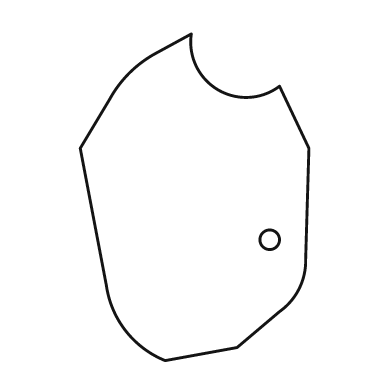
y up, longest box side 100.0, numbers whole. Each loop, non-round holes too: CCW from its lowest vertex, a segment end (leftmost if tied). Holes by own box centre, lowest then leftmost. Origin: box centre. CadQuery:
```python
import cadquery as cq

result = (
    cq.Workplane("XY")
    .moveTo(-9.0, -50.0)
    .lineTo(13.0, -46.0)
    .lineTo(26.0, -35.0)
    .threePointArc((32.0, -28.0), (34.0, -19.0))
    .lineTo(35.0, 15.0)
    .lineTo(26.0, 34.0)
    .threePointArc((7.0, 33.0), (-1.0, 50.0))
    .lineTo(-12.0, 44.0)
    .threePointArc((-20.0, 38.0), (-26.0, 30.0))
    .lineTo(-35.0, 15.0)
    .lineTo(-27.0, -27.0)
    .threePointArc((-21.0, -41.0), (-9.0, -50.0))
    .close()
    .moveTo(23.0, -13.0)
    .circle(3.0)
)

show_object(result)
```